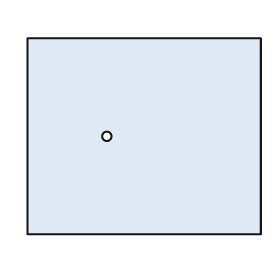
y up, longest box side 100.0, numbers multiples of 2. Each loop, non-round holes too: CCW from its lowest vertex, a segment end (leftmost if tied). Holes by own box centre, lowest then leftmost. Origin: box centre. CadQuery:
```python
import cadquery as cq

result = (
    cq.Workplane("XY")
    .moveTo(-50.0, -42.0)
    .lineTo(50.0, -42.0)
    .lineTo(50.0, 42.0)
    .lineTo(-50.0, 42.0)
    .close()
    .moveTo(-16.0, 0.0)
    .circle(2.0)
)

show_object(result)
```